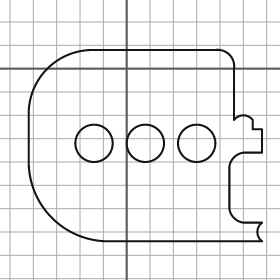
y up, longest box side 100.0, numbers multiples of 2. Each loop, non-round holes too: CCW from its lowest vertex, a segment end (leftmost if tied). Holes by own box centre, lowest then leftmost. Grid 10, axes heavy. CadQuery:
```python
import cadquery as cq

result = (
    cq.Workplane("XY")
    .moveTo(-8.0, -74.0)
    .lineTo(58.0, -74.0)
    .threePointArc((56.0, -70.0), (58.0, -66.0))
    .lineTo(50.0, -66.0)
    .threePointArc((46.0, -64.0), (44.0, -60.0))
    .lineTo(44.0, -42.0)
    .threePointArc((46.0, -38.0), (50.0, -36.0))
    .lineTo(58.0, -36.0)
    .lineTo(58.0, -26.0)
    .lineTo(54.0, -26.0)
    .lineTo(54.0, -22.0)
    .threePointArc((50.0, -20.0), (46.0, -22.0))
    .lineTo(46.0, 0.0)
    .threePointArc((44.0, 6.0), (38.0, 8.0))
    .lineTo(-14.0, 8.0)
    .threePointArc((-34.0, 0.0), (-42.0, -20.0))
    .lineTo(-42.0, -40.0)
    .threePointArc((-32.0, -64.0), (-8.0, -74.0))
    .close()
    .moveTo(-14.0, -32.0)
    .circle(8.0)
    .moveTo(8.0, -32.0)
    .circle(8.0)
    .moveTo(30.0, -32.0)
    .circle(8.0)
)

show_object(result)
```